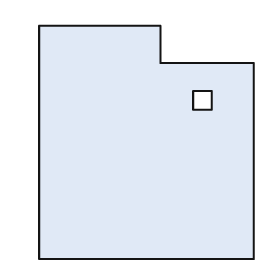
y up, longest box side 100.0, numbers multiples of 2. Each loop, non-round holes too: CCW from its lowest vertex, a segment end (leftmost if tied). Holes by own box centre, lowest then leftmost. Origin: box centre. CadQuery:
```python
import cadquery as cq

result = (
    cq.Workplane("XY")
    .moveTo(-46.0, -50.0)
    .lineTo(46.0, -50.0)
    .lineTo(46.0, 34.0)
    .lineTo(6.0, 34.0)
    .lineTo(6.0, 50.0)
    .lineTo(-46.0, 50.0)
    .close()
    .moveTo(20.0, 14.0)
    .lineTo(28.0, 14.0)
    .lineTo(28.0, 22.0)
    .lineTo(20.0, 22.0)
    .close()
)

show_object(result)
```